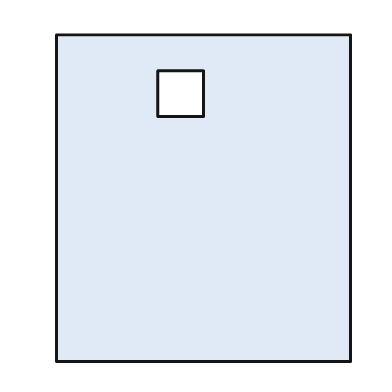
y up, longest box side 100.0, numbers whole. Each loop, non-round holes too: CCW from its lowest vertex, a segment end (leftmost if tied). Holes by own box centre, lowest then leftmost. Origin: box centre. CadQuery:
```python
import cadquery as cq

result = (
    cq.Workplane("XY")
    .moveTo(-45.0, -50.0)
    .lineTo(45.0, -50.0)
    .lineTo(45.0, 50.0)
    .lineTo(-45.0, 50.0)
    .close()
    .moveTo(-14.0, 25.0)
    .lineTo(0.0, 25.0)
    .lineTo(0.0, 39.0)
    .lineTo(-14.0, 39.0)
    .close()
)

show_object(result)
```